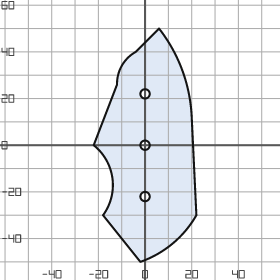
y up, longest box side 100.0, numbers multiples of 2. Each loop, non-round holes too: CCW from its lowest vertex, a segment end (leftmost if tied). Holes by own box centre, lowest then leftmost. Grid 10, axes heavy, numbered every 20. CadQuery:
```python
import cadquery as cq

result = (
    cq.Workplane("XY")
    .moveTo(-2.0, -50.0)
    .threePointArc((12.0, -42.0), (22.0, -30.0))
    .lineTo(20.0, 12.0)
    .threePointArc((16.0, 32.0), (6.0, 50.0))
    .lineTo(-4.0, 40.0)
    .threePointArc((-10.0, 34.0), (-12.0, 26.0))
    .lineTo(-22.0, 0.0)
    .threePointArc((-14.0, -14.0), (-18.0, -30.0))
    .close()
    .moveTo(0.0, -22.0)
    .circle(2.0)
    .moveTo(0.0, 0.0)
    .circle(2.0)
    .moveTo(0.0, 22.0)
    .circle(2.0)
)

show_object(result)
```